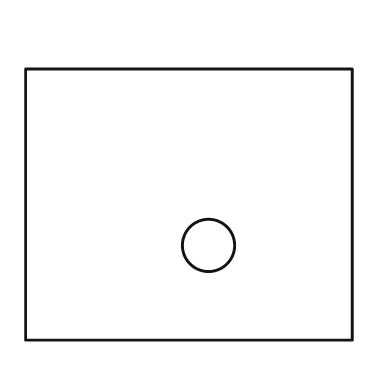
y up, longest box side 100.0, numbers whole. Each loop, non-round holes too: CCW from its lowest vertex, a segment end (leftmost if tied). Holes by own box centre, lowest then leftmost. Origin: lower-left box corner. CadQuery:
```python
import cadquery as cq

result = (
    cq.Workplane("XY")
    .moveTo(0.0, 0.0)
    .lineTo(100.0, 0.0)
    .lineTo(100.0, 83.0)
    .lineTo(0.0, 83.0)
    .close()
    .moveTo(56.0, 29.0)
    .circle(8.0)
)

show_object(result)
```